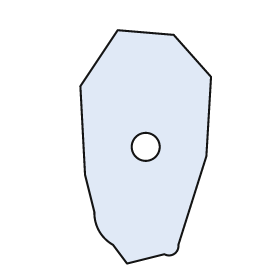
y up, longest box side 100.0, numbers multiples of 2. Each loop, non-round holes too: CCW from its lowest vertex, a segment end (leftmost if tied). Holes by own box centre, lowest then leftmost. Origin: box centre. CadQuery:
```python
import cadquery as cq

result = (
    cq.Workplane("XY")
    .moveTo(-8.0, -50.0)
    .lineTo(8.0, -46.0)
    .threePointArc((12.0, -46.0), (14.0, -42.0))
    .lineTo(26.0, -4.0)
    .lineTo(28.0, 30.0)
    .lineTo(12.0, 48.0)
    .lineTo(-12.0, 50.0)
    .lineTo(-28.0, 26.0)
    .lineTo(-26.0, -12.0)
    .lineTo(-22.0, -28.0)
    .threePointArc((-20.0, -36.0), (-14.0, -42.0))
    .close()
    .moveTo(0.0, 0.0)
    .circle(6.0)
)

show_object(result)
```